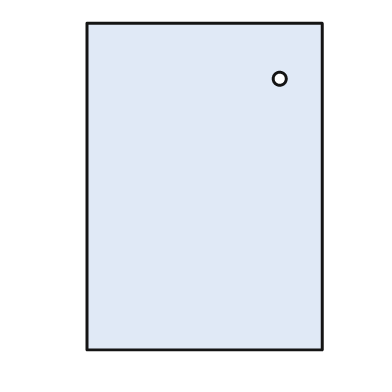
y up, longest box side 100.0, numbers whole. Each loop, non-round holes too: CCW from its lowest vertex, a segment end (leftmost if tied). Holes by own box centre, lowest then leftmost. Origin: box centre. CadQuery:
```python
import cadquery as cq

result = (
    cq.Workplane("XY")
    .moveTo(-36.0, -50.0)
    .lineTo(36.0, -50.0)
    .lineTo(36.0, 50.0)
    .lineTo(-36.0, 50.0)
    .close()
    .moveTo(23.0, 33.0)
    .circle(2.0)
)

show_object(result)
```